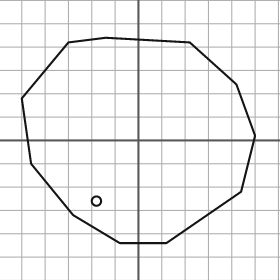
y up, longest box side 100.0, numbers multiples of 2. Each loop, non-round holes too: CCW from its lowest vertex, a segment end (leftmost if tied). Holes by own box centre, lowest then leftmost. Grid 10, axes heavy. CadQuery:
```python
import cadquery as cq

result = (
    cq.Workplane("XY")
    .moveTo(-8.0, -44.0)
    .lineTo(12.0, -44.0)
    .lineTo(44.0, -22.0)
    .lineTo(50.0, 2.0)
    .lineTo(42.0, 24.0)
    .lineTo(22.0, 42.0)
    .lineTo(-14.0, 44.0)
    .lineTo(-30.0, 42.0)
    .lineTo(-50.0, 18.0)
    .lineTo(-46.0, -10.0)
    .lineTo(-28.0, -32.0)
    .close()
    .moveTo(-18.0, -26.0)
    .circle(2.0)
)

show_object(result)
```